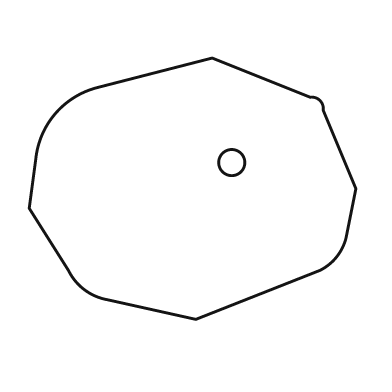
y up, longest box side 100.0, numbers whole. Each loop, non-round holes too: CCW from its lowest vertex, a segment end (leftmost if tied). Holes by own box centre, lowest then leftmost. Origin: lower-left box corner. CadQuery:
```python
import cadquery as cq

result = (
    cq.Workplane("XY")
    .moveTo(51.0, 0.0)
    .lineTo(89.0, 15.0)
    .threePointArc((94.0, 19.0), (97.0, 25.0))
    .lineTo(100.0, 40.0)
    .lineTo(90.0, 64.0)
    .threePointArc((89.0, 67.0), (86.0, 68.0))
    .lineTo(56.0, 80.0)
    .lineTo(21.0, 71.0)
    .threePointArc((8.0, 63.0), (2.0, 49.0))
    .lineTo(0.0, 34.0)
    .lineTo(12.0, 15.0)
    .threePointArc((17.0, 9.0), (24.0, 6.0))
    .close()
    .moveTo(62.0, 48.0)
    .circle(4.0)
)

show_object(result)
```